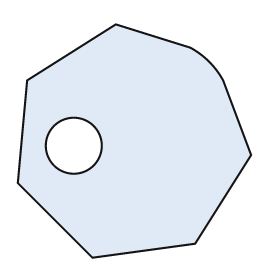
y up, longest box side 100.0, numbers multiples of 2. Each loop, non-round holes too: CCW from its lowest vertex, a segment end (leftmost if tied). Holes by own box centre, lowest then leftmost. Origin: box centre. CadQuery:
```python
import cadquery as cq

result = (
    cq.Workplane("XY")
    .moveTo(-18.0, -50.0)
    .lineTo(26.0, -44.0)
    .lineTo(50.0, -6.0)
    .lineTo(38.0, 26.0)
    .threePointArc((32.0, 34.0), (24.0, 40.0))
    .lineTo(-8.0, 50.0)
    .lineTo(-46.0, 26.0)
    .lineTo(-50.0, -18.0)
    .close()
    .moveTo(-26.0, -2.0)
    .circle(12.0)
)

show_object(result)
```